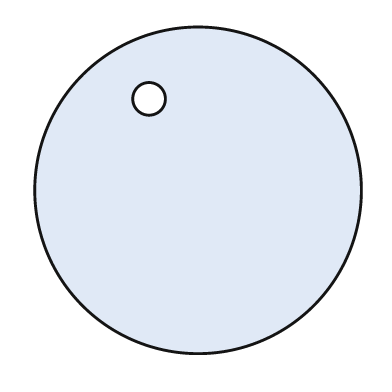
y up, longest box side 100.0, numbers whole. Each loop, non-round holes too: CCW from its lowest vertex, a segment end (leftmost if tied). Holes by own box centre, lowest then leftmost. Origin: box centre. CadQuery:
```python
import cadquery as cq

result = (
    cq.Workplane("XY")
    .moveTo(0.0, 0.0)
    .circle(50.0)
    .moveTo(-15.0, 28.0)
    .circle(5.0)
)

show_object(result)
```